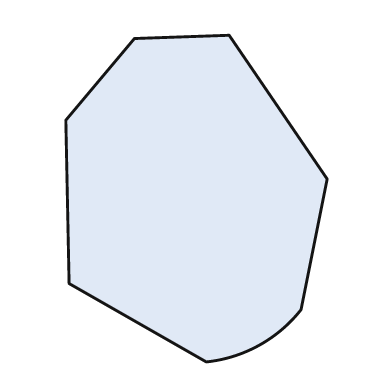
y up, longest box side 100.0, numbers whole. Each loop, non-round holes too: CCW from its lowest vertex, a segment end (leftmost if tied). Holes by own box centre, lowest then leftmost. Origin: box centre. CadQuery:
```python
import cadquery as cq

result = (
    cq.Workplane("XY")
    .moveTo(3.0, -50.0)
    .threePointArc((19.0, -45.0), (32.0, -34.0))
    .lineTo(40.0, 6.0)
    .lineTo(10.0, 50.0)
    .lineTo(-19.0, 49.0)
    .lineTo(-40.0, 24.0)
    .lineTo(-39.0, -26.0)
    .close()
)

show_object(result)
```